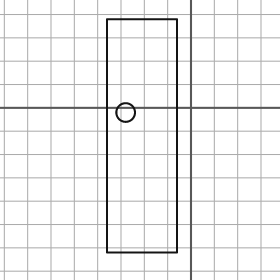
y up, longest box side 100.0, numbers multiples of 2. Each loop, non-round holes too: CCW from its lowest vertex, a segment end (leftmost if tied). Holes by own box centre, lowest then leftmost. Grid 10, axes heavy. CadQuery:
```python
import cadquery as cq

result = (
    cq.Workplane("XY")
    .moveTo(-36.0, -62.0)
    .lineTo(-6.0, -62.0)
    .lineTo(-6.0, 38.0)
    .lineTo(-36.0, 38.0)
    .close()
    .moveTo(-28.0, -2.0)
    .circle(4.0)
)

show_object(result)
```